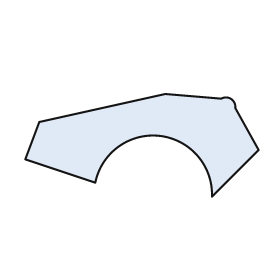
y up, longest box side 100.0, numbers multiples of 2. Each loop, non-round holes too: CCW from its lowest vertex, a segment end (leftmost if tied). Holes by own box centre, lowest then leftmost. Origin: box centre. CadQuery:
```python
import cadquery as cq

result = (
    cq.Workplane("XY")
    .moveTo(30.0, -22.0)
    .lineTo(50.0, -2.0)
    .lineTo(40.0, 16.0)
    .threePointArc((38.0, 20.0), (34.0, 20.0))
    .lineTo(10.0, 22.0)
    .lineTo(-44.0, 10.0)
    .lineTo(-50.0, -6.0)
    .lineTo(-20.0, -16.0)
    .threePointArc((8.0, 4.0), (30.0, -22.0))
    .close()
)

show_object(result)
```